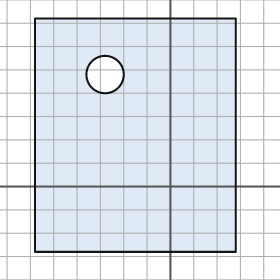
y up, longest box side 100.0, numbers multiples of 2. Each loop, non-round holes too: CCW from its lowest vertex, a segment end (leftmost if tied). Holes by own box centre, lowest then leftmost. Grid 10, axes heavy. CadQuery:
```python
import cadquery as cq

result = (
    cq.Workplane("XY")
    .moveTo(-58.0, -28.0)
    .lineTo(28.0, -28.0)
    .lineTo(28.0, 72.0)
    .lineTo(-58.0, 72.0)
    .close()
    .moveTo(-28.0, 48.0)
    .circle(8.0)
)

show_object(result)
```